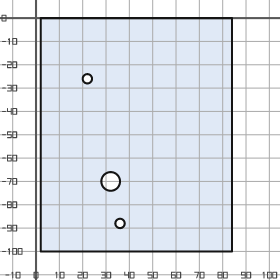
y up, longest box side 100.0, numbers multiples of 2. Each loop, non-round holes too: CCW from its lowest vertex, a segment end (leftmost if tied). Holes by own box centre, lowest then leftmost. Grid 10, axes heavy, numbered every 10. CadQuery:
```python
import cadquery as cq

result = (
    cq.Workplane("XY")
    .moveTo(2.0, -100.0)
    .lineTo(84.0, -100.0)
    .lineTo(84.0, 0.0)
    .lineTo(2.0, 0.0)
    .close()
    .moveTo(36.0, -88.0)
    .circle(2.0)
    .moveTo(32.0, -70.0)
    .circle(4.0)
    .moveTo(22.0, -26.0)
    .circle(2.0)
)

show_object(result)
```